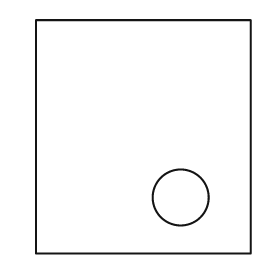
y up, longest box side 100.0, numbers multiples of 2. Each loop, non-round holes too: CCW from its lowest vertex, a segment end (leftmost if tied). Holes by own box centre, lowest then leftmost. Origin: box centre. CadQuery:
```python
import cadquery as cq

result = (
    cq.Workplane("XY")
    .moveTo(-46.0, -50.0)
    .lineTo(46.0, -50.0)
    .lineTo(46.0, 50.0)
    .lineTo(-46.0, 50.0)
    .close()
    .moveTo(16.0, -26.0)
    .circle(12.0)
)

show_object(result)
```